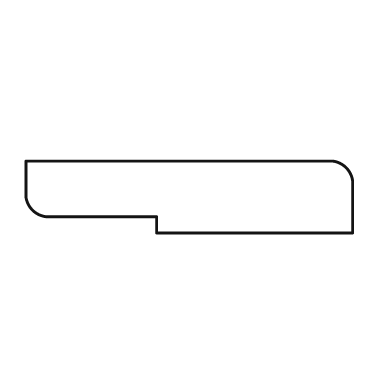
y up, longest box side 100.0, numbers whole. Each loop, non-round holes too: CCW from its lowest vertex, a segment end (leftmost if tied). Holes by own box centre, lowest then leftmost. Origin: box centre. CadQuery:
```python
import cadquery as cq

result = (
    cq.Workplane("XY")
    .moveTo(-10.0, -11.0)
    .lineTo(50.0, -11.0)
    .lineTo(50.0, 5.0)
    .threePointArc((48.0, 9.0), (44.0, 11.0))
    .lineTo(-50.0, 11.0)
    .lineTo(-50.0, 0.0)
    .threePointArc((-48.0, -4.0), (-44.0, -6.0))
    .lineTo(-10.0, -6.0)
    .close()
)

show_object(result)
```